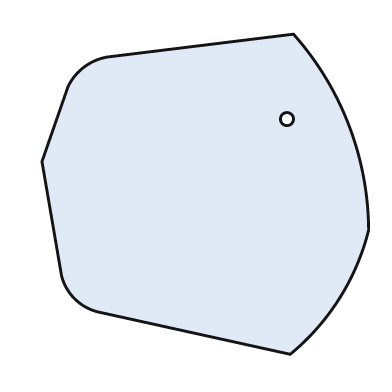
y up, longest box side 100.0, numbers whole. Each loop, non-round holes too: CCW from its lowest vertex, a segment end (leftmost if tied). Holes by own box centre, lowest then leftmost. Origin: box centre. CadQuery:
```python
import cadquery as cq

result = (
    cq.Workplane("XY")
    .moveTo(26.0, -49.0)
    .threePointArc((41.0, -32.0), (50.0, -11.0))
    .threePointArc((44.0, 21.0), (27.0, 49.0))
    .lineTo(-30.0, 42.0)
    .threePointArc((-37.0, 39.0), (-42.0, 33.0))
    .lineTo(-50.0, 10.0)
    .lineTo(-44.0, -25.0)
    .threePointArc((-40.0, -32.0), (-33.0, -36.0))
    .close()
    .moveTo(25.0, 23.0)
    .circle(2.0)
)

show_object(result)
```